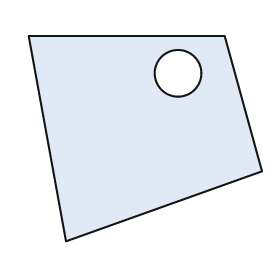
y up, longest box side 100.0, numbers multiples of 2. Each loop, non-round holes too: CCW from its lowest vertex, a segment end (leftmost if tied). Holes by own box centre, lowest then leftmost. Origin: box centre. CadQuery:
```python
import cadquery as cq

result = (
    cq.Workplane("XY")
    .moveTo(-34.0, -44.0)
    .lineTo(50.0, -14.0)
    .lineTo(34.0, 44.0)
    .lineTo(-50.0, 44.0)
    .close()
    .moveTo(14.0, 28.0)
    .circle(10.0)
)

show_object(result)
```